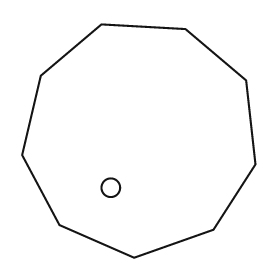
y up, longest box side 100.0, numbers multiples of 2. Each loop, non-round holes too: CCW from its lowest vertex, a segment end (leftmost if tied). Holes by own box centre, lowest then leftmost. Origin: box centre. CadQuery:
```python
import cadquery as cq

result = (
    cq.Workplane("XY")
    .moveTo(-2.0, -50.0)
    .lineTo(32.0, -38.0)
    .lineTo(50.0, -10.0)
    .lineTo(46.0, 26.0)
    .lineTo(20.0, 48.0)
    .lineTo(-16.0, 50.0)
    .lineTo(-42.0, 28.0)
    .lineTo(-50.0, -6.0)
    .lineTo(-34.0, -36.0)
    .close()
    .moveTo(-12.0, -20.0)
    .circle(4.0)
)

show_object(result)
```